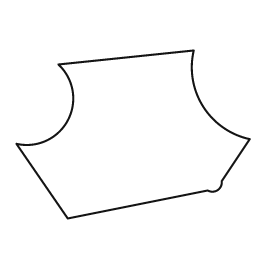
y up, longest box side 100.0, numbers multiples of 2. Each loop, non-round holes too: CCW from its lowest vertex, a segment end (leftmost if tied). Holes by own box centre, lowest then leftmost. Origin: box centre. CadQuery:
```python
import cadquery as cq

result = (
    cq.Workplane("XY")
    .moveTo(-28.0, -36.0)
    .lineTo(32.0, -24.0)
    .threePointArc((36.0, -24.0), (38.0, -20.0))
    .lineTo(50.0, -2.0)
    .threePointArc((30.0, 12.0), (26.0, 36.0))
    .lineTo(-32.0, 30.0)
    .threePointArc((-28.0, 6.0), (-50.0, -4.0))
    .close()
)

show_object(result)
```